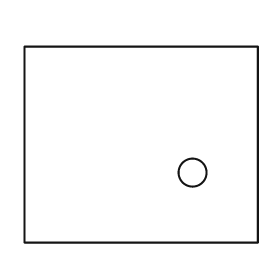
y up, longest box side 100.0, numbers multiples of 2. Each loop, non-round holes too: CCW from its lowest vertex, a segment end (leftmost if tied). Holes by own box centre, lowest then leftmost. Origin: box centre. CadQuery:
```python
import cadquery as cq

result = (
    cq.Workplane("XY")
    .moveTo(-50.0, -42.0)
    .lineTo(50.0, -42.0)
    .lineTo(50.0, 42.0)
    .lineTo(-50.0, 42.0)
    .close()
    .moveTo(22.0, -12.0)
    .circle(6.0)
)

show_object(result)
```